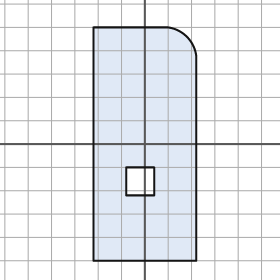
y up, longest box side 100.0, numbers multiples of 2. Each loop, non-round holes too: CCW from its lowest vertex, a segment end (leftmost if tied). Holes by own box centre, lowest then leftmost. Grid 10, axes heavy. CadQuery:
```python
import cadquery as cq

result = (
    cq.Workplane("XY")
    .moveTo(-22.0, -50.0)
    .lineTo(22.0, -50.0)
    .lineTo(22.0, 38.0)
    .threePointArc((18.0, 46.0), (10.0, 50.0))
    .lineTo(-22.0, 50.0)
    .close()
    .moveTo(-8.0, -22.0)
    .lineTo(4.0, -22.0)
    .lineTo(4.0, -10.0)
    .lineTo(-8.0, -10.0)
    .close()
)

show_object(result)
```